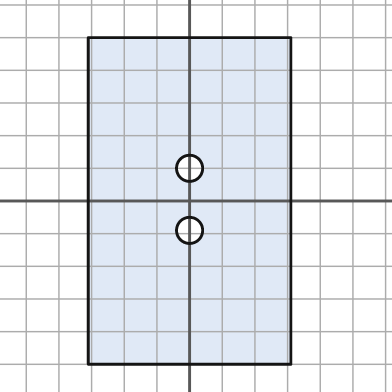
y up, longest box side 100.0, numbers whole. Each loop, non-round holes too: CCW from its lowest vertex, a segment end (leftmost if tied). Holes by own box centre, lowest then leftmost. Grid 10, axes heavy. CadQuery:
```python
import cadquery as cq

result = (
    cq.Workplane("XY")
    .moveTo(-31.0, -50.0)
    .lineTo(31.0, -50.0)
    .lineTo(31.0, 50.0)
    .lineTo(-31.0, 50.0)
    .close()
    .moveTo(0.0, -9.0)
    .circle(4.0)
    .moveTo(0.0, 10.0)
    .circle(4.0)
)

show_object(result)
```